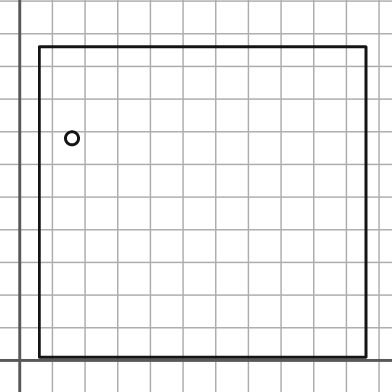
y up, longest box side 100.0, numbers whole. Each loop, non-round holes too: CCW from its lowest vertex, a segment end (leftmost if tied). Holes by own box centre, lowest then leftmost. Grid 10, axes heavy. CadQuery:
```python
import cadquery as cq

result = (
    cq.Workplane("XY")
    .moveTo(6.0, 1.0)
    .lineTo(106.0, 1.0)
    .lineTo(106.0, 96.0)
    .lineTo(6.0, 96.0)
    .close()
    .moveTo(16.0, 68.0)
    .circle(2.0)
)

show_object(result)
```